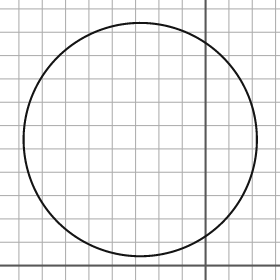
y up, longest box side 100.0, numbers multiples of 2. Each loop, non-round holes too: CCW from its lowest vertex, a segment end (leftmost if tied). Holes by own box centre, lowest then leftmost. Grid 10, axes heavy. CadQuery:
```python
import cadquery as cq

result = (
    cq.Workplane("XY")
    .moveTo(-28.0, 54.0)
    .circle(50.0)
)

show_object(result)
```